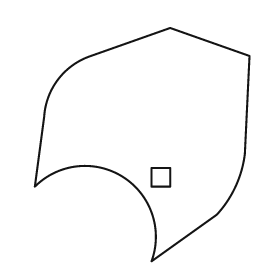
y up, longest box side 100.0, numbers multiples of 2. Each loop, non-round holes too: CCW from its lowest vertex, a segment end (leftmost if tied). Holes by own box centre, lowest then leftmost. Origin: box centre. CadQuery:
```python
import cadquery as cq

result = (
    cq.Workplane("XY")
    .moveTo(4.0, -50.0)
    .lineTo(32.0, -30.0)
    .threePointArc((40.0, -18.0), (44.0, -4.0))
    .lineTo(46.0, 38.0)
    .lineTo(12.0, 50.0)
    .lineTo(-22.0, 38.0)
    .threePointArc((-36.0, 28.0), (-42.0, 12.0))
    .lineTo(-46.0, -18.0)
    .threePointArc((-8.0, -14.0), (4.0, -50.0))
    .close()
    .moveTo(4.0, -18.0)
    .lineTo(12.0, -18.0)
    .lineTo(12.0, -10.0)
    .lineTo(4.0, -10.0)
    .close()
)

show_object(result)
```